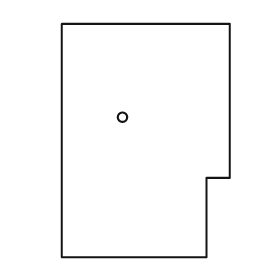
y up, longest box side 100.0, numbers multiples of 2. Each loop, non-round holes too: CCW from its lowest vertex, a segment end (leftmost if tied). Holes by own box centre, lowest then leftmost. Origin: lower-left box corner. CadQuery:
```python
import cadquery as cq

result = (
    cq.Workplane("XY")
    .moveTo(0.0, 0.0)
    .lineTo(62.0, 0.0)
    .lineTo(62.0, 34.0)
    .lineTo(72.0, 34.0)
    .lineTo(72.0, 100.0)
    .lineTo(0.0, 100.0)
    .close()
    .moveTo(26.0, 60.0)
    .circle(2.0)
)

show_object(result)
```